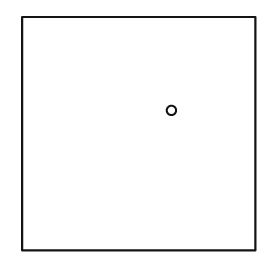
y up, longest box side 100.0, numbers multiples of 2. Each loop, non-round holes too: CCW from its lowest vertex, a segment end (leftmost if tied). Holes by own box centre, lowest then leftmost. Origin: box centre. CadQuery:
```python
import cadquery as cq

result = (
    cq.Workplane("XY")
    .moveTo(-50.0, -50.0)
    .lineTo(50.0, -50.0)
    .lineTo(50.0, 50.0)
    .lineTo(-50.0, 50.0)
    .close()
    .moveTo(14.0, 10.0)
    .circle(2.0)
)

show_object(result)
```